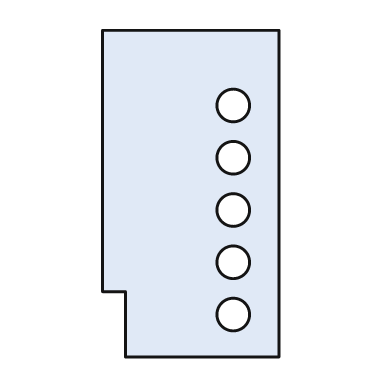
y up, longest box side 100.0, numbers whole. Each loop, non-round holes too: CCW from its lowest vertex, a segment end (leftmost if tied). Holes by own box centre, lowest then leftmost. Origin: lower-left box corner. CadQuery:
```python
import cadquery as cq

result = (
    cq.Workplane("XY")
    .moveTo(7.0, 0.0)
    .lineTo(54.0, 0.0)
    .lineTo(54.0, 100.0)
    .lineTo(0.0, 100.0)
    .lineTo(0.0, 20.0)
    .lineTo(7.0, 20.0)
    .close()
    .moveTo(40.0, 13.0)
    .circle(5.0)
    .moveTo(40.0, 29.0)
    .circle(5.0)
    .moveTo(40.0, 45.0)
    .circle(5.0)
    .moveTo(40.0, 61.0)
    .circle(5.0)
    .moveTo(40.0, 77.0)
    .circle(5.0)
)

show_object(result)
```